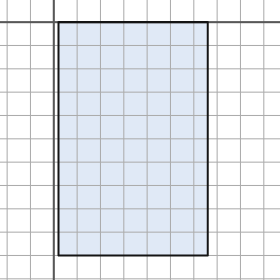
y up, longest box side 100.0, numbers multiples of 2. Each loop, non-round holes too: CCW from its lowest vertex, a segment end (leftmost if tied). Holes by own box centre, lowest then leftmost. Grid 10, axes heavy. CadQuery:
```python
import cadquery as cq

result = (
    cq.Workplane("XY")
    .moveTo(2.0, -100.0)
    .lineTo(66.0, -100.0)
    .lineTo(66.0, 0.0)
    .lineTo(2.0, 0.0)
    .close()
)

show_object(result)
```